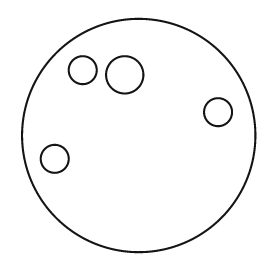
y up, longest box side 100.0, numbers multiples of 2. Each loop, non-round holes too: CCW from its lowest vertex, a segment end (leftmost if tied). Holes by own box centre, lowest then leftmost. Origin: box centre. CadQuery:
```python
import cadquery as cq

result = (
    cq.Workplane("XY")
    .moveTo(0.0, 0.0)
    .circle(50.0)
    .moveTo(-36.0, -10.0)
    .circle(6.0)
    .moveTo(34.0, 10.0)
    .circle(6.0)
    .moveTo(-6.0, 26.0)
    .circle(8.0)
    .moveTo(-24.0, 28.0)
    .circle(6.0)
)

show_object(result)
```